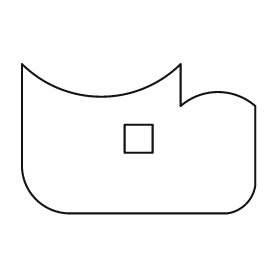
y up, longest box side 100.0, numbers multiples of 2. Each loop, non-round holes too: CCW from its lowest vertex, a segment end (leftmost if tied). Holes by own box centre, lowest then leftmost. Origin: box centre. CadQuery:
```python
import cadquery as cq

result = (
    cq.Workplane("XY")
    .moveTo(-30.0, -32.0)
    .lineTo(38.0, -32.0)
    .threePointArc((46.0, -28.0), (50.0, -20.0))
    .lineTo(50.0, 14.0)
    .threePointArc((34.0, 20.0), (18.0, 14.0))
    .lineTo(18.0, 32.0)
    .threePointArc((-16.0, 18.0), (-50.0, 32.0))
    .lineTo(-50.0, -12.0)
    .threePointArc((-44.0, -26.0), (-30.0, -32.0))
    .close()
    .moveTo(-6.0, -6.0)
    .lineTo(6.0, -6.0)
    .lineTo(6.0, 6.0)
    .lineTo(-6.0, 6.0)
    .close()
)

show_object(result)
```